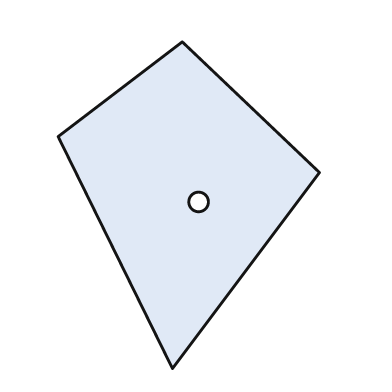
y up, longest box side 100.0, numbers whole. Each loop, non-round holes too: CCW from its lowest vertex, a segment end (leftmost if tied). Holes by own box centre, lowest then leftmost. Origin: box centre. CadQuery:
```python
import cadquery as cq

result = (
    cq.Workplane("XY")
    .moveTo(-5.0, -50.0)
    .lineTo(40.0, 10.0)
    .lineTo(-2.0, 50.0)
    .lineTo(-40.0, 21.0)
    .close()
    .moveTo(3.0, 1.0)
    .circle(3.0)
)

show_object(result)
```